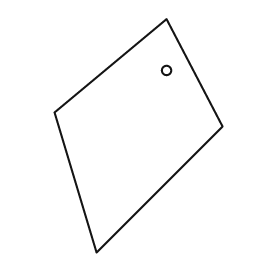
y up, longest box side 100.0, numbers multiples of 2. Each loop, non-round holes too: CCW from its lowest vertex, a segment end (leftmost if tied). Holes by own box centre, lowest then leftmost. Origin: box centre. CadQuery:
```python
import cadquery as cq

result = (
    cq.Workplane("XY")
    .moveTo(-18.0, -50.0)
    .lineTo(36.0, 4.0)
    .lineTo(12.0, 50.0)
    .lineTo(-36.0, 10.0)
    .close()
    .moveTo(12.0, 28.0)
    .circle(2.0)
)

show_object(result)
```